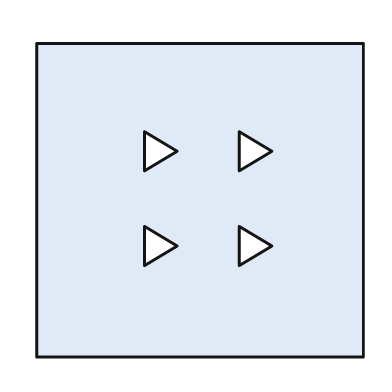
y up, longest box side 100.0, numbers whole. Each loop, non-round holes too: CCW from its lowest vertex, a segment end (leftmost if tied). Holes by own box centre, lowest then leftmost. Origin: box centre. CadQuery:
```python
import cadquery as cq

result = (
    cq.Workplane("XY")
    .moveTo(-50.0, -48.0)
    .lineTo(50.0, -48.0)
    .lineTo(50.0, 48.0)
    .lineTo(-50.0, 48.0)
    .close()
    .moveTo(-17.0, -20.0)
    .lineTo(-7.0, -14.0)
    .lineTo(-17.0, -8.0)
    .close()
    .moveTo(12.0, -20.0)
    .lineTo(22.0, -14.0)
    .lineTo(12.0, -8.0)
    .close()
    .moveTo(-17.0, 9.0)
    .lineTo(-7.0, 15.0)
    .lineTo(-17.0, 21.0)
    .close()
    .moveTo(12.0, 9.0)
    .lineTo(22.0, 15.0)
    .lineTo(12.0, 21.0)
    .close()
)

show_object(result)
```